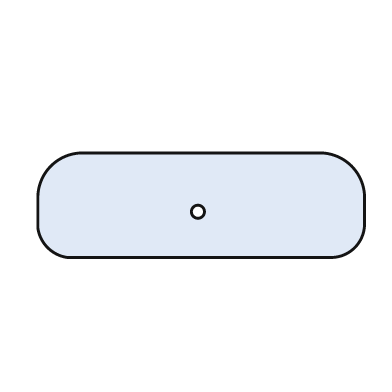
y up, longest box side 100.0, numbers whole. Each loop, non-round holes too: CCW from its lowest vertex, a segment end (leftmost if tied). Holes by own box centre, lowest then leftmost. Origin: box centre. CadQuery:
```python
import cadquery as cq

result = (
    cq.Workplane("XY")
    .moveTo(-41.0, -16.0)
    .lineTo(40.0, -16.0)
    .threePointArc((47.0, -13.0), (50.0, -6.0))
    .lineTo(50.0, 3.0)
    .threePointArc((46.0, 12.0), (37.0, 16.0))
    .lineTo(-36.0, 16.0)
    .threePointArc((-46.0, 12.0), (-50.0, 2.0))
    .lineTo(-50.0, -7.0)
    .threePointArc((-47.0, -13.0), (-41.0, -16.0))
    .close()
    .moveTo(-1.0, -2.0)
    .circle(2.0)
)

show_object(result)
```